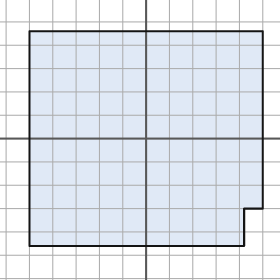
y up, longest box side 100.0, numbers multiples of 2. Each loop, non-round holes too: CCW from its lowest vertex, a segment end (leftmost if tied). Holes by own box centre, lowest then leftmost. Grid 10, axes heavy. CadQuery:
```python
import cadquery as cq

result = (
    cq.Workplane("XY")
    .moveTo(-50.0, -46.0)
    .lineTo(42.0, -46.0)
    .lineTo(42.0, -30.0)
    .lineTo(50.0, -30.0)
    .lineTo(50.0, 46.0)
    .lineTo(-50.0, 46.0)
    .close()
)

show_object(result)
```